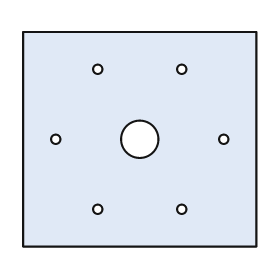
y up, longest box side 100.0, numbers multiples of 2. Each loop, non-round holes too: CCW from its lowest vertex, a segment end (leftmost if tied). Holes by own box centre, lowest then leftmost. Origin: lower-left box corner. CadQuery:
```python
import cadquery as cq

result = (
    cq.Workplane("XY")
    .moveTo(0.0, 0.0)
    .lineTo(100.0, 0.0)
    .lineTo(100.0, 92.0)
    .lineTo(0.0, 92.0)
    .close()
    .moveTo(32.0, 16.0)
    .circle(2.0)
    .moveTo(68.0, 16.0)
    .circle(2.0)
    .moveTo(14.0, 46.0)
    .circle(2.0)
    .moveTo(50.0, 46.0)
    .circle(8.0)
    .moveTo(86.0, 46.0)
    .circle(2.0)
    .moveTo(32.0, 76.0)
    .circle(2.0)
    .moveTo(68.0, 76.0)
    .circle(2.0)
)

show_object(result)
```